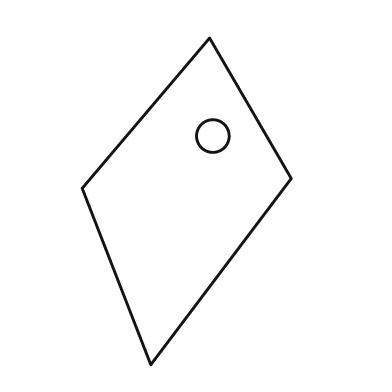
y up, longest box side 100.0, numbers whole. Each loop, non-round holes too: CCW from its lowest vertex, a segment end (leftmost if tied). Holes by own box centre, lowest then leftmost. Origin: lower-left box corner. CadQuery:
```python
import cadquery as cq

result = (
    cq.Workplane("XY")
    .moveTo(21.0, 0.0)
    .lineTo(64.0, 57.0)
    .lineTo(39.0, 100.0)
    .lineTo(0.0, 54.0)
    .close()
    .moveTo(40.0, 70.0)
    .circle(5.0)
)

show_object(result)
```